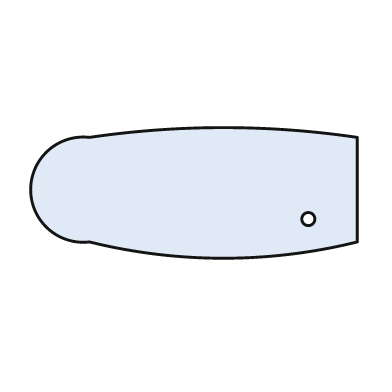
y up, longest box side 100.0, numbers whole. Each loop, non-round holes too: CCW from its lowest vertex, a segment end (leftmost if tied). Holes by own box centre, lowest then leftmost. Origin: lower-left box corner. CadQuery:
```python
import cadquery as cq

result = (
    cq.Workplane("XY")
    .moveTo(18.0, 5.0)
    .threePointArc((59.0, 0.0), (100.0, 5.0))
    .lineTo(100.0, 37.0)
    .threePointArc((59.0, 40.0), (18.0, 37.0))
    .threePointArc((0.0, 21.0), (18.0, 5.0))
    .close()
    .moveTo(85.0, 12.0)
    .circle(2.0)
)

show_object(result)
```